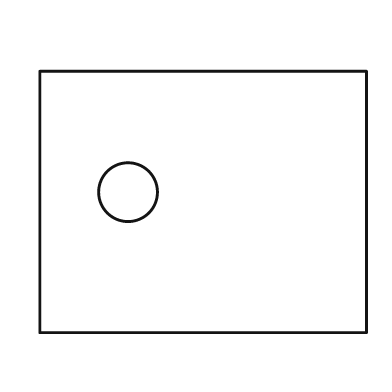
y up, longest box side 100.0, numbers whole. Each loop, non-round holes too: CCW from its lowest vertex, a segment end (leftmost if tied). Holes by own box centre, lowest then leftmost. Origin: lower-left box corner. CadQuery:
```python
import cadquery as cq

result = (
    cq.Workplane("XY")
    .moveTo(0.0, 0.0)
    .lineTo(100.0, 0.0)
    .lineTo(100.0, 80.0)
    .lineTo(0.0, 80.0)
    .close()
    .moveTo(27.0, 43.0)
    .circle(9.0)
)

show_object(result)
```